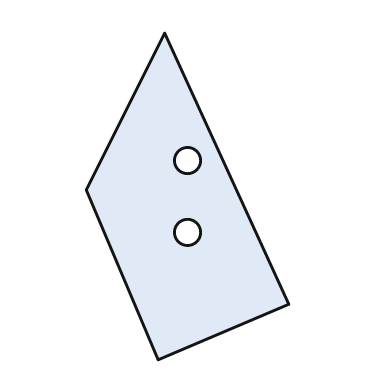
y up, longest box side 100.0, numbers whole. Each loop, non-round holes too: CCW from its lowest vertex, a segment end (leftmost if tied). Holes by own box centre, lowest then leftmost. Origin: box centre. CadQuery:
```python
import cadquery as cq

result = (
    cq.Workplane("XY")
    .moveTo(-9.0, -50.0)
    .lineTo(31.0, -33.0)
    .lineTo(-7.0, 50.0)
    .lineTo(-31.0, 2.0)
    .close()
    .moveTo(0.0, -11.0)
    .circle(4.0)
    .moveTo(0.0, 11.0)
    .circle(4.0)
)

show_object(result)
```